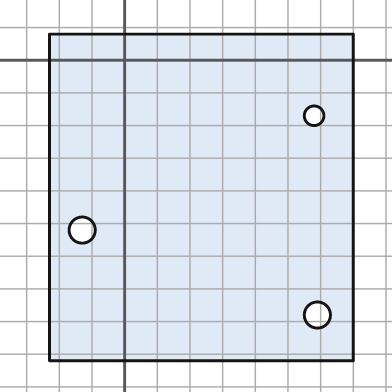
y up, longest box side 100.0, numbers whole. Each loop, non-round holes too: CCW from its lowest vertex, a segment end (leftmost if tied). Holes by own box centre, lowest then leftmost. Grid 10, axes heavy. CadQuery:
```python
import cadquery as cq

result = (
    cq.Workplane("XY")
    .moveTo(-23.0, -92.0)
    .lineTo(70.0, -92.0)
    .lineTo(70.0, 8.0)
    .lineTo(-23.0, 8.0)
    .close()
    .moveTo(59.0, -78.0)
    .circle(4.0)
    .moveTo(-13.0, -52.0)
    .circle(4.0)
    .moveTo(58.0, -17.0)
    .circle(3.0)
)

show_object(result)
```